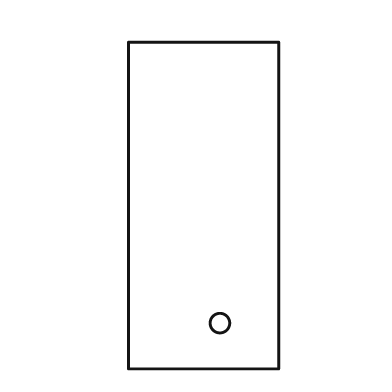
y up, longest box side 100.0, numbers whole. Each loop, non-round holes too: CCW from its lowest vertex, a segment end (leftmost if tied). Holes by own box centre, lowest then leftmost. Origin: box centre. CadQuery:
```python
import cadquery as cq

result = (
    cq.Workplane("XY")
    .moveTo(-23.0, -50.0)
    .lineTo(23.0, -50.0)
    .lineTo(23.0, 50.0)
    .lineTo(-23.0, 50.0)
    .close()
    .moveTo(5.0, -36.0)
    .circle(3.0)
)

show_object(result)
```